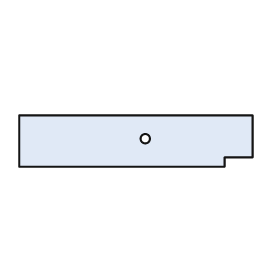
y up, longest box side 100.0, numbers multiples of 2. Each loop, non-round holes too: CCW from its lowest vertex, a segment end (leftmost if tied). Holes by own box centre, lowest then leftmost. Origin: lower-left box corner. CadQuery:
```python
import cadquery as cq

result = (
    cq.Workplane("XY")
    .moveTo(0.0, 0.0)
    .lineTo(88.0, 0.0)
    .lineTo(88.0, 4.0)
    .lineTo(100.0, 4.0)
    .lineTo(100.0, 22.0)
    .lineTo(0.0, 22.0)
    .close()
    .moveTo(54.0, 12.0)
    .circle(2.0)
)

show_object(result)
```